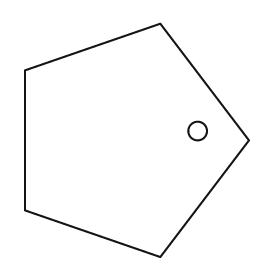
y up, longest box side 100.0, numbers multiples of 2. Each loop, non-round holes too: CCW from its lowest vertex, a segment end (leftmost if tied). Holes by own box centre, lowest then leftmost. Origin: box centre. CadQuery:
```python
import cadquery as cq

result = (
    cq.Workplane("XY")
    .moveTo(10.0, -50.0)
    .lineTo(48.0, 0.0)
    .lineTo(10.0, 50.0)
    .lineTo(-48.0, 30.0)
    .lineTo(-48.0, -30.0)
    .close()
    .moveTo(26.0, 4.0)
    .circle(4.0)
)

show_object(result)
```